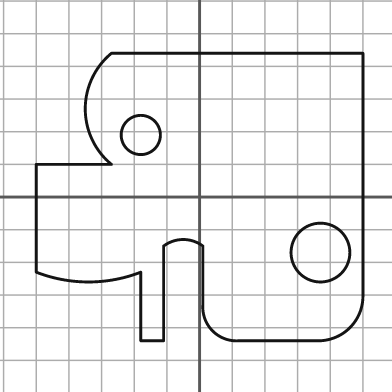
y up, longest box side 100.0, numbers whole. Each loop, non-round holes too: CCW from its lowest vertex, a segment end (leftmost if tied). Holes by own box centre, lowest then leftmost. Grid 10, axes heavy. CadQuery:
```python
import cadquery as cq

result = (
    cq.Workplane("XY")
    .moveTo(-18.0, -44.0)
    .lineTo(-11.0, -44.0)
    .lineTo(-11.0, -15.0)
    .threePointArc((-5.0, -13.0), (1.0, -15.0))
    .lineTo(1.0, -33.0)
    .threePointArc((4.0, -41.0), (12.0, -44.0))
    .lineTo(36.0, -44.0)
    .threePointArc((46.0, -40.0), (50.0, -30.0))
    .lineTo(50.0, 44.0)
    .lineTo(-27.0, 44.0)
    .threePointArc((-35.0, 27.0), (-27.0, 10.0))
    .lineTo(-50.0, 10.0)
    .lineTo(-50.0, -23.0)
    .threePointArc((-34.0, -26.0), (-18.0, -23.0))
    .close()
    .moveTo(37.0, -17.0)
    .circle(9.0)
    .moveTo(-18.0, 19.0)
    .circle(6.0)
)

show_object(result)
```